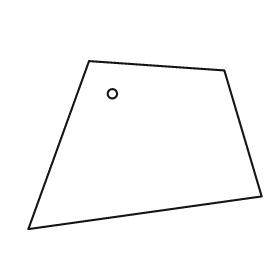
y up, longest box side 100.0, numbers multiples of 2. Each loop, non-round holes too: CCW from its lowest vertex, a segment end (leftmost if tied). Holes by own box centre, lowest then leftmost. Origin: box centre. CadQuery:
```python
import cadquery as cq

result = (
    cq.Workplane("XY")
    .moveTo(-50.0, -36.0)
    .lineTo(50.0, -22.0)
    .lineTo(34.0, 32.0)
    .lineTo(-24.0, 36.0)
    .close()
    .moveTo(-14.0, 22.0)
    .circle(2.0)
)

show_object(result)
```